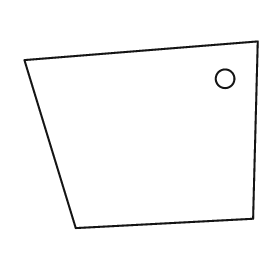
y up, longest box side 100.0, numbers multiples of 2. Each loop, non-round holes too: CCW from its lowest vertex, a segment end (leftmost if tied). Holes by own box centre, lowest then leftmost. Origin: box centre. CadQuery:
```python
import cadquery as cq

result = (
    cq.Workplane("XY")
    .moveTo(-28.0, -40.0)
    .lineTo(48.0, -36.0)
    .lineTo(50.0, 40.0)
    .lineTo(-50.0, 32.0)
    .close()
    .moveTo(36.0, 24.0)
    .circle(4.0)
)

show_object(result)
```